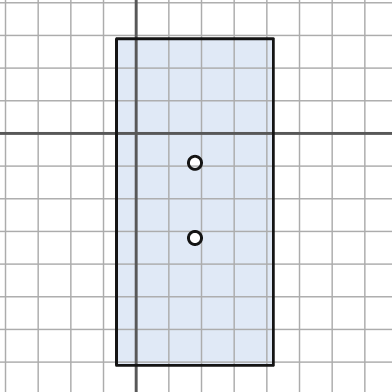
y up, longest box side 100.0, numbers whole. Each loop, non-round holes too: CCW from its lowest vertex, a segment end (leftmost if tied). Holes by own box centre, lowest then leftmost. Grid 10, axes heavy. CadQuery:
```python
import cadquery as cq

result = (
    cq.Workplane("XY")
    .moveTo(-6.0, -71.0)
    .lineTo(42.0, -71.0)
    .lineTo(42.0, 29.0)
    .lineTo(-6.0, 29.0)
    .close()
    .moveTo(18.0, -32.0)
    .circle(2.0)
    .moveTo(18.0, -9.0)
    .circle(2.0)
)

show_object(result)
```